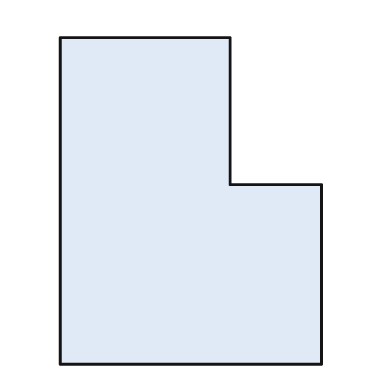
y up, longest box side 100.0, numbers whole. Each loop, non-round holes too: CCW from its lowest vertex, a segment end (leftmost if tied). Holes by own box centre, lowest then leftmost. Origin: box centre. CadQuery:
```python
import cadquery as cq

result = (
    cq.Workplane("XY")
    .moveTo(-40.0, -50.0)
    .lineTo(40.0, -50.0)
    .lineTo(40.0, 5.0)
    .lineTo(12.0, 5.0)
    .lineTo(12.0, 50.0)
    .lineTo(-40.0, 50.0)
    .close()
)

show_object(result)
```